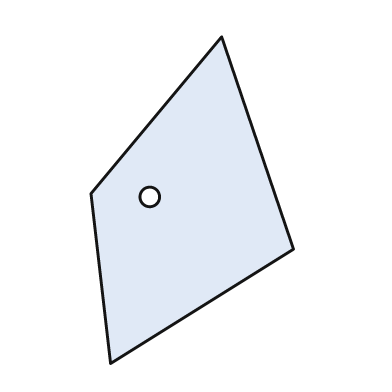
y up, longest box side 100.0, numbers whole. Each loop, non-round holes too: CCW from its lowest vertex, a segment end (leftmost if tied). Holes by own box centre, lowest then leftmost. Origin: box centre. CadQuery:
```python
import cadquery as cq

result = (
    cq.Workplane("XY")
    .moveTo(-25.0, -50.0)
    .lineTo(31.0, -15.0)
    .lineTo(9.0, 50.0)
    .lineTo(-31.0, 2.0)
    .close()
    .moveTo(-13.0, 1.0)
    .circle(3.0)
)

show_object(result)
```